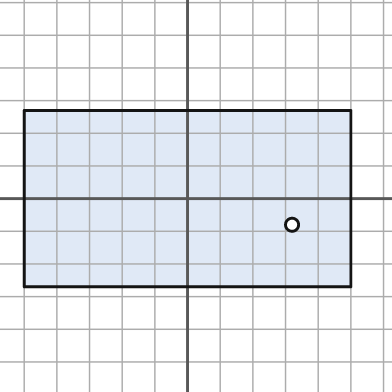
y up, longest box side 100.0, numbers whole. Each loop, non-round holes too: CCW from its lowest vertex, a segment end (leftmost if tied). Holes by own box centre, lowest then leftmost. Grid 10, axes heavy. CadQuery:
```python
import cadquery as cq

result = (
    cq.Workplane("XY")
    .moveTo(-50.0, -27.0)
    .lineTo(50.0, -27.0)
    .lineTo(50.0, 27.0)
    .lineTo(-50.0, 27.0)
    .close()
    .moveTo(32.0, -8.0)
    .circle(2.0)
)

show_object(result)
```